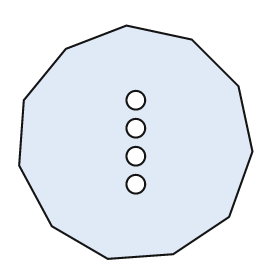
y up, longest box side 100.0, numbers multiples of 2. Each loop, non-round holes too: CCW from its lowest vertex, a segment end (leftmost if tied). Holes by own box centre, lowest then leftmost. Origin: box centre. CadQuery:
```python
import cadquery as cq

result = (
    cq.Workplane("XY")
    .moveTo(-12.0, -50.0)
    .lineTo(16.0, -48.0)
    .lineTo(40.0, -32.0)
    .lineTo(50.0, -4.0)
    .lineTo(44.0, 24.0)
    .lineTo(24.0, 44.0)
    .lineTo(-4.0, 50.0)
    .lineTo(-30.0, 40.0)
    .lineTo(-48.0, 18.0)
    .lineTo(-50.0, -10.0)
    .lineTo(-36.0, -36.0)
    .close()
    .moveTo(0.0, -18.0)
    .circle(4.0)
    .moveTo(0.0, -6.0)
    .circle(4.0)
    .moveTo(0.0, 6.0)
    .circle(4.0)
    .moveTo(0.0, 18.0)
    .circle(4.0)
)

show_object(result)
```